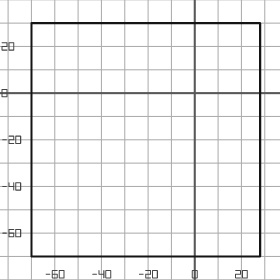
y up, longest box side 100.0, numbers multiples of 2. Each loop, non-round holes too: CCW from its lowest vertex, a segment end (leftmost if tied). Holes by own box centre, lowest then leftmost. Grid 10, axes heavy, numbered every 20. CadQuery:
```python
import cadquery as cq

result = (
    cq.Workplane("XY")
    .moveTo(-70.0, -70.0)
    .lineTo(28.0, -70.0)
    .lineTo(28.0, 30.0)
    .lineTo(-70.0, 30.0)
    .close()
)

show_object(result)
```